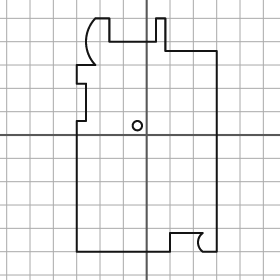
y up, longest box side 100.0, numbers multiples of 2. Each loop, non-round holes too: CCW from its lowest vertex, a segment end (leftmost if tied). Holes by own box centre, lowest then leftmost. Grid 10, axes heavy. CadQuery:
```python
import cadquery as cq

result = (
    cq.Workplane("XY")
    .moveTo(-30.0, -50.0)
    .lineTo(10.0, -50.0)
    .lineTo(10.0, -42.0)
    .lineTo(24.0, -42.0)
    .threePointArc((22.0, -46.0), (24.0, -50.0))
    .lineTo(30.0, -50.0)
    .lineTo(30.0, 36.0)
    .lineTo(8.0, 36.0)
    .lineTo(8.0, 50.0)
    .lineTo(4.0, 50.0)
    .lineTo(4.0, 40.0)
    .lineTo(-16.0, 40.0)
    .lineTo(-16.0, 50.0)
    .lineTo(-22.0, 50.0)
    .threePointArc((-26.0, 40.0), (-22.0, 30.0))
    .lineTo(-30.0, 30.0)
    .lineTo(-30.0, 22.0)
    .lineTo(-26.0, 22.0)
    .lineTo(-26.0, 6.0)
    .lineTo(-30.0, 6.0)
    .close()
    .moveTo(-4.0, 4.0)
    .circle(2.0)
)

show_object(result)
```